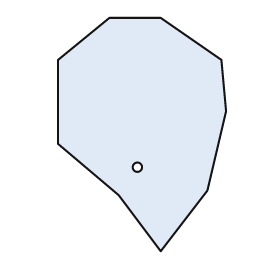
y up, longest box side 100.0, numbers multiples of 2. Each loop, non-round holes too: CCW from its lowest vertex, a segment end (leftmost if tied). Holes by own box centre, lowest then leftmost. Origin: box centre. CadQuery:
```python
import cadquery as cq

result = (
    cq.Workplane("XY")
    .moveTo(8.0, -50.0)
    .lineTo(28.0, -24.0)
    .lineTo(36.0, 10.0)
    .lineTo(34.0, 32.0)
    .lineTo(8.0, 50.0)
    .lineTo(-14.0, 50.0)
    .lineTo(-36.0, 32.0)
    .lineTo(-36.0, -4.0)
    .lineTo(-10.0, -26.0)
    .close()
    .moveTo(-2.0, -14.0)
    .circle(2.0)
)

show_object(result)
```